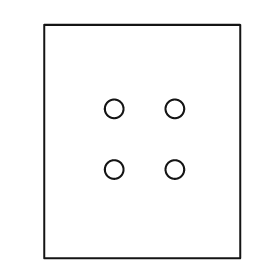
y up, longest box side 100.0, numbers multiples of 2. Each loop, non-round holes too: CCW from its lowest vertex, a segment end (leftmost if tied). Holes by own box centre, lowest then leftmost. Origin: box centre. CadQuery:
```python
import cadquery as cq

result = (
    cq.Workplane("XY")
    .moveTo(-42.0, -50.0)
    .lineTo(42.0, -50.0)
    .lineTo(42.0, 50.0)
    .lineTo(-42.0, 50.0)
    .close()
    .moveTo(-12.0, -12.0)
    .circle(4.0)
    .moveTo(14.0, -12.0)
    .circle(4.0)
    .moveTo(-12.0, 14.0)
    .circle(4.0)
    .moveTo(14.0, 14.0)
    .circle(4.0)
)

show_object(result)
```